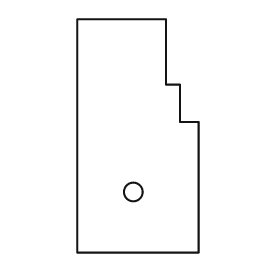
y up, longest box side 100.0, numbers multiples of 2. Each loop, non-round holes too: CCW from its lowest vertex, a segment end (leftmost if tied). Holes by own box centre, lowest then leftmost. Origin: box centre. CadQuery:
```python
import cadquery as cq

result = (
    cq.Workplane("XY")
    .moveTo(-26.0, -50.0)
    .lineTo(26.0, -50.0)
    .lineTo(26.0, 6.0)
    .lineTo(18.0, 6.0)
    .lineTo(18.0, 22.0)
    .lineTo(12.0, 22.0)
    .lineTo(12.0, 50.0)
    .lineTo(-26.0, 50.0)
    .close()
    .moveTo(-2.0, -24.0)
    .circle(4.0)
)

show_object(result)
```